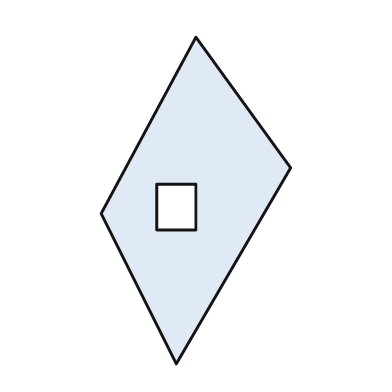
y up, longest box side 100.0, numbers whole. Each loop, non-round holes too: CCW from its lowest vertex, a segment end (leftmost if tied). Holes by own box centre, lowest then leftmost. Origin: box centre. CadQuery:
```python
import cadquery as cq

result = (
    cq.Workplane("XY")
    .moveTo(-6.0, -50.0)
    .lineTo(29.0, 10.0)
    .lineTo(0.0, 50.0)
    .lineTo(-29.0, -4.0)
    .close()
    .moveTo(-12.0, -9.0)
    .lineTo(0.0, -9.0)
    .lineTo(0.0, 5.0)
    .lineTo(-12.0, 5.0)
    .close()
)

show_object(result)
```